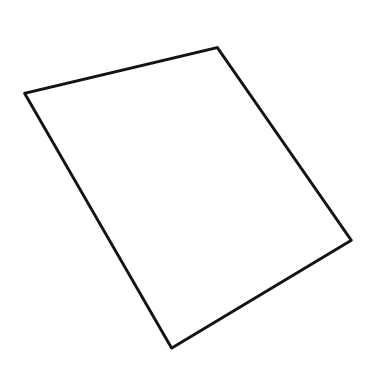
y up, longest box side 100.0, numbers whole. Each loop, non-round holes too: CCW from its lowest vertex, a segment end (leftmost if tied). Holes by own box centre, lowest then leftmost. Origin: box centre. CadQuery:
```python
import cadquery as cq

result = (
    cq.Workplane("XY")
    .moveTo(-5.0, -46.0)
    .lineTo(50.0, -13.0)
    .lineTo(9.0, 46.0)
    .lineTo(-50.0, 32.0)
    .close()
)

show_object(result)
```